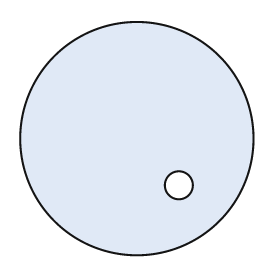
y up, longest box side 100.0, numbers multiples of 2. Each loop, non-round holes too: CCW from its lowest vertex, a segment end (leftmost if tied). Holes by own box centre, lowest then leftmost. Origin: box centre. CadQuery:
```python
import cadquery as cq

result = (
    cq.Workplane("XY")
    .moveTo(0.0, 0.0)
    .circle(50.0)
    .moveTo(18.0, -20.0)
    .circle(6.0)
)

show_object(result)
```